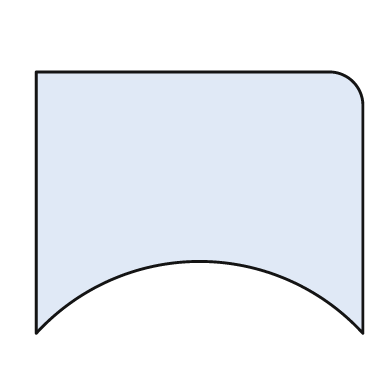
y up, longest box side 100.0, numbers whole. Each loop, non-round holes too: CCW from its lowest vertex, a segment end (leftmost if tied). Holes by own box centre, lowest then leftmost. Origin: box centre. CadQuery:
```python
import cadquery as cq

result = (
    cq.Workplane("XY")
    .moveTo(-50.0, -40.0)
    .threePointArc((0.0, -18.0), (50.0, -40.0))
    .lineTo(50.0, 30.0)
    .threePointArc((47.0, 37.0), (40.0, 40.0))
    .lineTo(-50.0, 40.0)
    .close()
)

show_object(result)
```